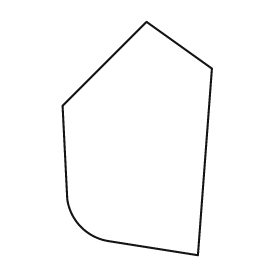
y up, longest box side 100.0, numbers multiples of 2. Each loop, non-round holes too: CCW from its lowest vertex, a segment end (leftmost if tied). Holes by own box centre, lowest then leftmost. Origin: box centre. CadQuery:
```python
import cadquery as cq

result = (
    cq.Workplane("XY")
    .moveTo(26.0, -50.0)
    .lineTo(32.0, 30.0)
    .lineTo(4.0, 50.0)
    .lineTo(-32.0, 14.0)
    .lineTo(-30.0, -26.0)
    .threePointArc((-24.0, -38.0), (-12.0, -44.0))
    .close()
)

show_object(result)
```